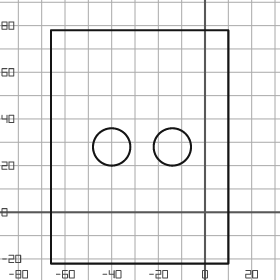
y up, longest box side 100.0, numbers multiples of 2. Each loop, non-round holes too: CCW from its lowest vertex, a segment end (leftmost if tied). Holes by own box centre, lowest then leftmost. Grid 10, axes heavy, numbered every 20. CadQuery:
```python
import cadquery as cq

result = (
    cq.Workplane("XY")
    .moveTo(-66.0, -22.0)
    .lineTo(10.0, -22.0)
    .lineTo(10.0, 78.0)
    .lineTo(-66.0, 78.0)
    .close()
    .moveTo(-40.0, 28.0)
    .circle(8.0)
    .moveTo(-14.0, 28.0)
    .circle(8.0)
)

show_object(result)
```